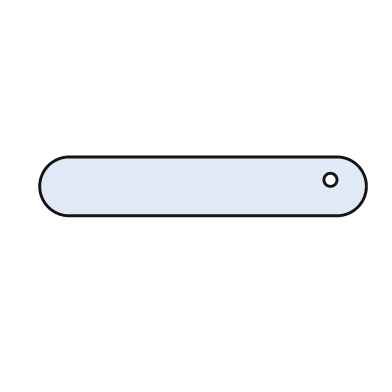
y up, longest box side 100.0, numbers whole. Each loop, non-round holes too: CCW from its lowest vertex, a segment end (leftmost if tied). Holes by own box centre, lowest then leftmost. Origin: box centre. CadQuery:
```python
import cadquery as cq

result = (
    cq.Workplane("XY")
    .moveTo(-41.0, -9.0)
    .lineTo(41.0, -9.0)
    .threePointArc((50.0, 0.0), (41.0, 9.0))
    .lineTo(-41.0, 9.0)
    .threePointArc((-50.0, 0.0), (-41.0, -9.0))
    .close()
    .moveTo(39.0, 2.0)
    .circle(2.0)
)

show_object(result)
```